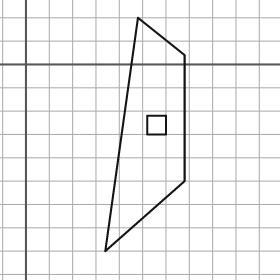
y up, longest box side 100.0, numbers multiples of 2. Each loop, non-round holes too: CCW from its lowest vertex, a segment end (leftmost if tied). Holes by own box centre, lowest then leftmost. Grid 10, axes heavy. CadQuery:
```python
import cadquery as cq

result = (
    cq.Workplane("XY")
    .moveTo(34.0, -80.0)
    .lineTo(68.0, -50.0)
    .lineTo(68.0, 4.0)
    .lineTo(48.0, 20.0)
    .close()
    .moveTo(52.0, -30.0)
    .lineTo(60.0, -30.0)
    .lineTo(60.0, -22.0)
    .lineTo(52.0, -22.0)
    .close()
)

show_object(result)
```